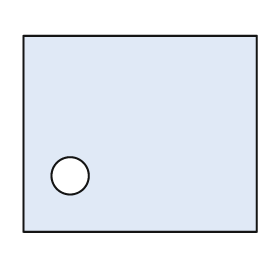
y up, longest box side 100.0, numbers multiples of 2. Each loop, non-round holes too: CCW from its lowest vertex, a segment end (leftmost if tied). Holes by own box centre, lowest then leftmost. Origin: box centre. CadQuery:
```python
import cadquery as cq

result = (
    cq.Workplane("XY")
    .moveTo(-50.0, -42.0)
    .lineTo(50.0, -42.0)
    .lineTo(50.0, 42.0)
    .lineTo(-50.0, 42.0)
    .close()
    .moveTo(-30.0, -18.0)
    .circle(8.0)
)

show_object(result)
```